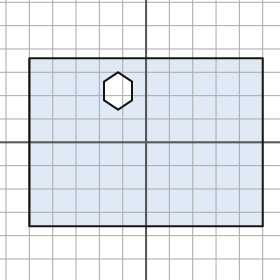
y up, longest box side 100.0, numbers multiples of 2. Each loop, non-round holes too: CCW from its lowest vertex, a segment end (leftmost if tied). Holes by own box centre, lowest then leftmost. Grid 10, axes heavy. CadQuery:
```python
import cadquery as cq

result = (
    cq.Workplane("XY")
    .moveTo(-50.0, -36.0)
    .lineTo(50.0, -36.0)
    .lineTo(50.0, 36.0)
    .lineTo(-50.0, 36.0)
    .close()
    .moveTo(-12.0, 14.0)
    .lineTo(-6.0, 18.0)
    .lineTo(-6.0, 26.0)
    .lineTo(-12.0, 30.0)
    .lineTo(-18.0, 26.0)
    .lineTo(-18.0, 18.0)
    .close()
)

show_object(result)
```